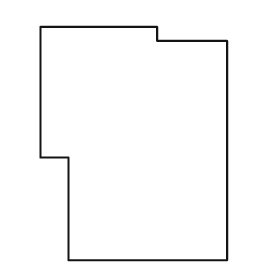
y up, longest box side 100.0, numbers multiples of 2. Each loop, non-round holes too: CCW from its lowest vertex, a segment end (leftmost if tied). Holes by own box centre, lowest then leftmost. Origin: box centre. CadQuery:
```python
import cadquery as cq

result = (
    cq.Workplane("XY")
    .moveTo(-28.0, -50.0)
    .lineTo(40.0, -50.0)
    .lineTo(40.0, 44.0)
    .lineTo(10.0, 44.0)
    .lineTo(10.0, 50.0)
    .lineTo(-40.0, 50.0)
    .lineTo(-40.0, -6.0)
    .lineTo(-28.0, -6.0)
    .close()
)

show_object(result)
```